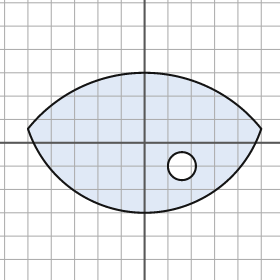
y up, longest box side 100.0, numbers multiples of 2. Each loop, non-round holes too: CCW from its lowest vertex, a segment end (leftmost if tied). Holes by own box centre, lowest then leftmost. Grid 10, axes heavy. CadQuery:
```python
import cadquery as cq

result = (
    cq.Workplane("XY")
    .moveTo(-50.0, 6.0)
    .threePointArc((0.0, -30.0), (50.0, 6.0))
    .threePointArc((0.0, 30.0), (-50.0, 6.0))
    .close()
    .moveTo(16.0, -10.0)
    .circle(6.0)
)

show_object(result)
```